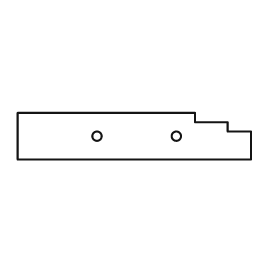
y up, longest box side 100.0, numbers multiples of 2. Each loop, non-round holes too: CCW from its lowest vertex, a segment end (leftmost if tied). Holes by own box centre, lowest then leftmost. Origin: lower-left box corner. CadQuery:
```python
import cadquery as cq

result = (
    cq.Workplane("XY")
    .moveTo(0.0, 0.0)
    .lineTo(100.0, 0.0)
    .lineTo(100.0, 12.0)
    .lineTo(90.0, 12.0)
    .lineTo(90.0, 16.0)
    .lineTo(76.0, 16.0)
    .lineTo(76.0, 20.0)
    .lineTo(0.0, 20.0)
    .close()
    .moveTo(34.0, 10.0)
    .circle(2.0)
    .moveTo(68.0, 10.0)
    .circle(2.0)
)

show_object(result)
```